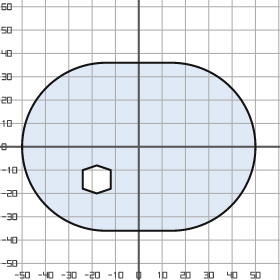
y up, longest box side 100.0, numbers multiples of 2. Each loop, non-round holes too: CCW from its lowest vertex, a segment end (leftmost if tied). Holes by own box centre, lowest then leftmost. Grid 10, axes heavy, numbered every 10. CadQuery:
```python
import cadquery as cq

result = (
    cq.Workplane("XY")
    .moveTo(-14.0, -36.0)
    .lineTo(14.0, -36.0)
    .threePointArc((50.0, 0.0), (14.0, 36.0))
    .lineTo(-14.0, 36.0)
    .threePointArc((-50.0, 0.0), (-14.0, -36.0))
    .close()
    .moveTo(-18.0, -20.0)
    .lineTo(-12.0, -18.0)
    .lineTo(-12.0, -10.0)
    .lineTo(-18.0, -8.0)
    .lineTo(-24.0, -10.0)
    .lineTo(-24.0, -18.0)
    .close()
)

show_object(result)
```